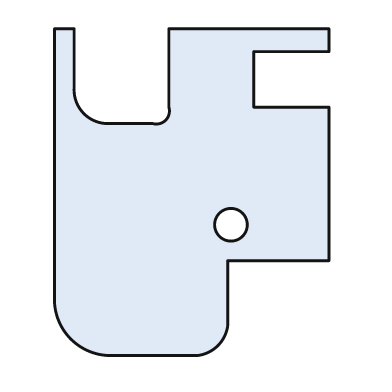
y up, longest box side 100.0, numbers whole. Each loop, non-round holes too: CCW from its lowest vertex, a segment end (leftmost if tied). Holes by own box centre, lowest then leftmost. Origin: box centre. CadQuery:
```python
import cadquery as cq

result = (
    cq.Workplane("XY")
    .moveTo(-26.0, -50.0)
    .lineTo(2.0, -50.0)
    .threePointArc((8.0, -47.0), (11.0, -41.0))
    .lineTo(11.0, -21.0)
    .lineTo(42.0, -21.0)
    .lineTo(42.0, 26.0)
    .lineTo(19.0, 26.0)
    .lineTo(19.0, 43.0)
    .lineTo(42.0, 43.0)
    .lineTo(42.0, 50.0)
    .lineTo(-7.0, 50.0)
    .lineTo(-7.0, 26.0)
    .threePointArc((-8.0, 22.0), (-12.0, 21.0))
    .lineTo(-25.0, 21.0)
    .threePointArc((-33.0, 24.0), (-36.0, 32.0))
    .lineTo(-36.0, 50.0)
    .lineTo(-42.0, 50.0)
    .lineTo(-42.0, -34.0)
    .threePointArc((-37.0, -45.0), (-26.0, -50.0))
    .close()
    .moveTo(12.0, -10.0)
    .circle(5.0)
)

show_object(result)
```